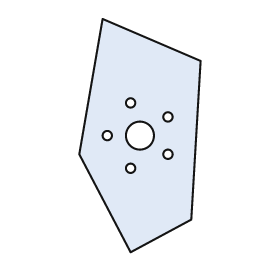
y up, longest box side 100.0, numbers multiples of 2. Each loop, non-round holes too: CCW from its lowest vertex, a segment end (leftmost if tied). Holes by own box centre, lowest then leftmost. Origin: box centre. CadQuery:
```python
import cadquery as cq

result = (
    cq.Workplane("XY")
    .moveTo(-4.0, -50.0)
    .lineTo(22.0, -36.0)
    .lineTo(26.0, 32.0)
    .lineTo(-16.0, 50.0)
    .lineTo(-26.0, -8.0)
    .close()
    .moveTo(-4.0, -14.0)
    .circle(2.0)
    .moveTo(12.0, -8.0)
    .circle(2.0)
    .moveTo(-14.0, 0.0)
    .circle(2.0)
    .moveTo(0.0, 0.0)
    .circle(6.0)
    .moveTo(12.0, 8.0)
    .circle(2.0)
    .moveTo(-4.0, 14.0)
    .circle(2.0)
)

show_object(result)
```